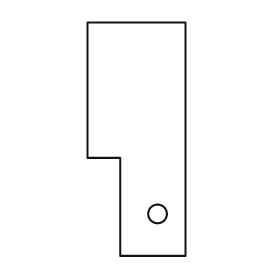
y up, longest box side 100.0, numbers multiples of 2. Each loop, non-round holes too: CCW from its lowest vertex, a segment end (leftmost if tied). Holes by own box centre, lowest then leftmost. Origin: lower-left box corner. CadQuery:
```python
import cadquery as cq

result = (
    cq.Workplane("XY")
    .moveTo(14.0, 0.0)
    .lineTo(42.0, 0.0)
    .lineTo(42.0, 100.0)
    .lineTo(0.0, 100.0)
    .lineTo(0.0, 42.0)
    .lineTo(14.0, 42.0)
    .close()
    .moveTo(30.0, 18.0)
    .circle(4.0)
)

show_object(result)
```